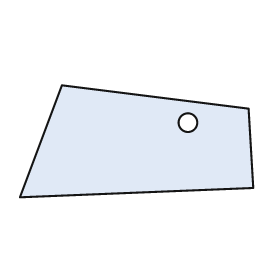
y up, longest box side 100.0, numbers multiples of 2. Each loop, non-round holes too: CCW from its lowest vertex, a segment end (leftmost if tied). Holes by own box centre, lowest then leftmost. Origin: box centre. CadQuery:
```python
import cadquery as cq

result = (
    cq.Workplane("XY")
    .moveTo(-50.0, -24.0)
    .lineTo(50.0, -20.0)
    .lineTo(48.0, 14.0)
    .lineTo(-32.0, 24.0)
    .close()
    .moveTo(22.0, 8.0)
    .circle(4.0)
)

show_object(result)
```